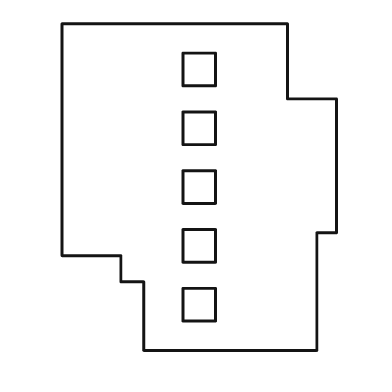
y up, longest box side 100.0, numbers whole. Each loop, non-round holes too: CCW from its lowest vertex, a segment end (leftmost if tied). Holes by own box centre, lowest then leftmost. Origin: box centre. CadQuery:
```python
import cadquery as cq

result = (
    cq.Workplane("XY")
    .moveTo(-17.0, -50.0)
    .lineTo(36.0, -50.0)
    .lineTo(36.0, -14.0)
    .lineTo(42.0, -14.0)
    .lineTo(42.0, 27.0)
    .lineTo(27.0, 27.0)
    .lineTo(27.0, 50.0)
    .lineTo(-42.0, 50.0)
    .lineTo(-42.0, -21.0)
    .lineTo(-24.0, -21.0)
    .lineTo(-24.0, -29.0)
    .lineTo(-17.0, -29.0)
    .close()
    .moveTo(-5.0, -41.0)
    .lineTo(5.0, -41.0)
    .lineTo(5.0, -31.0)
    .lineTo(-5.0, -31.0)
    .close()
    .moveTo(-5.0, -23.0)
    .lineTo(5.0, -23.0)
    .lineTo(5.0, -13.0)
    .lineTo(-5.0, -13.0)
    .close()
    .moveTo(-5.0, -5.0)
    .lineTo(5.0, -5.0)
    .lineTo(5.0, 5.0)
    .lineTo(-5.0, 5.0)
    .close()
    .moveTo(-5.0, 13.0)
    .lineTo(5.0, 13.0)
    .lineTo(5.0, 23.0)
    .lineTo(-5.0, 23.0)
    .close()
    .moveTo(-5.0, 31.0)
    .lineTo(5.0, 31.0)
    .lineTo(5.0, 41.0)
    .lineTo(-5.0, 41.0)
    .close()
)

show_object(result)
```